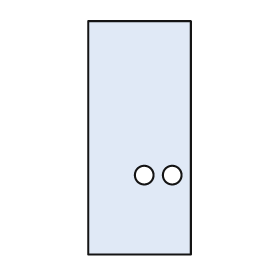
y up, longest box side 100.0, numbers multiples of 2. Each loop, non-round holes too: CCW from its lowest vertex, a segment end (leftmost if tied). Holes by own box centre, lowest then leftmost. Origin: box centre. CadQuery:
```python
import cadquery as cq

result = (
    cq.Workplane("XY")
    .moveTo(-22.0, -50.0)
    .lineTo(22.0, -50.0)
    .lineTo(22.0, 50.0)
    .lineTo(-22.0, 50.0)
    .close()
    .moveTo(2.0, -16.0)
    .circle(4.0)
    .moveTo(14.0, -16.0)
    .circle(4.0)
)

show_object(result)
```